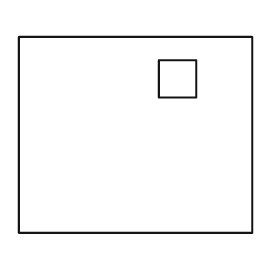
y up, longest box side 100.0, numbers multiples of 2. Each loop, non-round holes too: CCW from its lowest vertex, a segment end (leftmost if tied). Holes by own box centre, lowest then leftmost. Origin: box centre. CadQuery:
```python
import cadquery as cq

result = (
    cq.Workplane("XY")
    .moveTo(-50.0, -42.0)
    .lineTo(50.0, -42.0)
    .lineTo(50.0, 42.0)
    .lineTo(-50.0, 42.0)
    .close()
    .moveTo(10.0, 16.0)
    .lineTo(26.0, 16.0)
    .lineTo(26.0, 32.0)
    .lineTo(10.0, 32.0)
    .close()
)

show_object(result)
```